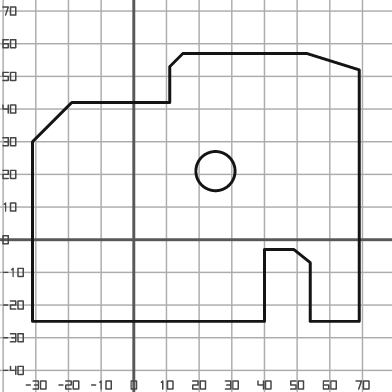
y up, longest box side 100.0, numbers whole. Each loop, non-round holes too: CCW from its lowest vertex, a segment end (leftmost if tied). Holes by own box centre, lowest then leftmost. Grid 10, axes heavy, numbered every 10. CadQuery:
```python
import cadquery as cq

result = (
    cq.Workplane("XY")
    .moveTo(-31.0, -25.0)
    .lineTo(40.0, -25.0)
    .lineTo(40.0, -3.0)
    .lineTo(49.0, -3.0)
    .lineTo(54.0, -7.0)
    .lineTo(54.0, -25.0)
    .lineTo(69.0, -25.0)
    .lineTo(69.0, 52.0)
    .lineTo(53.0, 57.0)
    .lineTo(15.0, 57.0)
    .lineTo(11.0, 53.0)
    .lineTo(11.0, 42.0)
    .lineTo(-19.0, 42.0)
    .lineTo(-31.0, 30.0)
    .close()
    .moveTo(25.0, 21.0)
    .circle(6.0)
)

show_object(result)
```